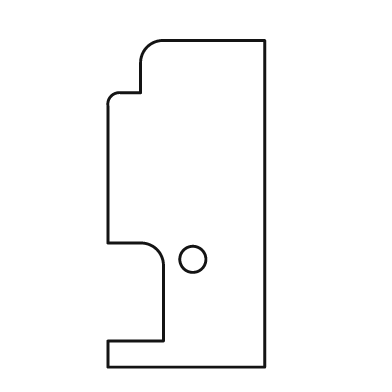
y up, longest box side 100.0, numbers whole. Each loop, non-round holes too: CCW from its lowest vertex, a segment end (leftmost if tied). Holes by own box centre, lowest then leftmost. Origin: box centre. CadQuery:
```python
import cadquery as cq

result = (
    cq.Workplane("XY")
    .moveTo(-24.0, -50.0)
    .lineTo(24.0, -50.0)
    .lineTo(24.0, 50.0)
    .lineTo(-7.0, 50.0)
    .threePointArc((-12.0, 48.0), (-14.0, 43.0))
    .lineTo(-14.0, 34.0)
    .lineTo(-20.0, 34.0)
    .threePointArc((-23.0, 33.0), (-24.0, 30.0))
    .lineTo(-24.0, -12.0)
    .lineTo(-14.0, -12.0)
    .threePointArc((-9.0, -14.0), (-7.0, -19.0))
    .lineTo(-7.0, -42.0)
    .lineTo(-24.0, -42.0)
    .close()
    .moveTo(2.0, -17.0)
    .circle(4.0)
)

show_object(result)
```